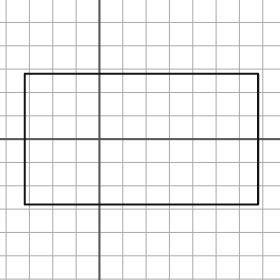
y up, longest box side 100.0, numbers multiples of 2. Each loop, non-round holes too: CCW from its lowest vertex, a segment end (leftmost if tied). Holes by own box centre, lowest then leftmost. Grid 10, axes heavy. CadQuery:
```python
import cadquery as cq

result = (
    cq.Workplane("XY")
    .moveTo(-32.0, -28.0)
    .lineTo(68.0, -28.0)
    .lineTo(68.0, 28.0)
    .lineTo(-32.0, 28.0)
    .close()
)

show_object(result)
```